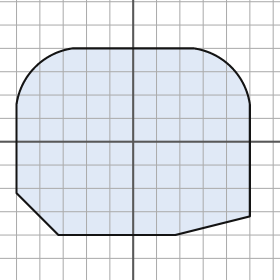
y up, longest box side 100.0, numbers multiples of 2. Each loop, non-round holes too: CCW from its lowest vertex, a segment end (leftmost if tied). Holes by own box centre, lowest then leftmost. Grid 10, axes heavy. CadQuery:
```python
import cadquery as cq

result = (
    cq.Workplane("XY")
    .moveTo(-32.0, -40.0)
    .lineTo(18.0, -40.0)
    .lineTo(50.0, -32.0)
    .lineTo(50.0, 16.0)
    .threePointArc((42.0, 32.0), (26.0, 40.0))
    .lineTo(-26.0, 40.0)
    .threePointArc((-42.0, 32.0), (-50.0, 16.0))
    .lineTo(-50.0, -22.0)
    .close()
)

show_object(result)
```